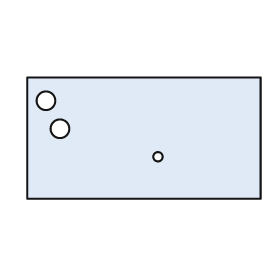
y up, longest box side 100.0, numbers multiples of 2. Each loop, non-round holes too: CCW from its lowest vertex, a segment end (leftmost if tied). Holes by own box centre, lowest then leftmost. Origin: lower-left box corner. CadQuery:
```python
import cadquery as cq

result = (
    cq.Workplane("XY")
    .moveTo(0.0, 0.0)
    .lineTo(100.0, 0.0)
    .lineTo(100.0, 52.0)
    .lineTo(0.0, 52.0)
    .close()
    .moveTo(56.0, 18.0)
    .circle(2.0)
    .moveTo(14.0, 30.0)
    .circle(4.0)
    .moveTo(8.0, 42.0)
    .circle(4.0)
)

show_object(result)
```